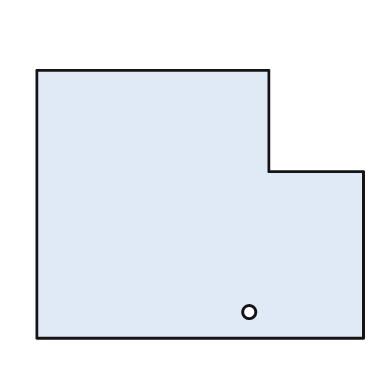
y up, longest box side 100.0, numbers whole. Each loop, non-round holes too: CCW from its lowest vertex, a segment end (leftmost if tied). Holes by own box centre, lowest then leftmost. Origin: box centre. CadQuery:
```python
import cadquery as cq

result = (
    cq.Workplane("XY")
    .moveTo(-50.0, -41.0)
    .lineTo(50.0, -41.0)
    .lineTo(50.0, 10.0)
    .lineTo(21.0, 10.0)
    .lineTo(21.0, 41.0)
    .lineTo(-50.0, 41.0)
    .close()
    .moveTo(15.0, -33.0)
    .circle(2.0)
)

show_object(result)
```